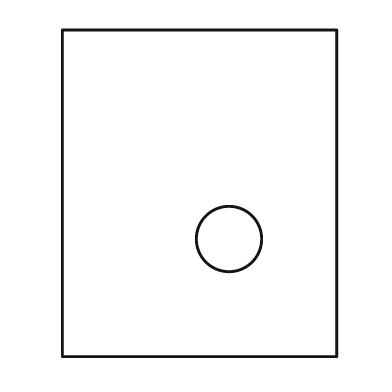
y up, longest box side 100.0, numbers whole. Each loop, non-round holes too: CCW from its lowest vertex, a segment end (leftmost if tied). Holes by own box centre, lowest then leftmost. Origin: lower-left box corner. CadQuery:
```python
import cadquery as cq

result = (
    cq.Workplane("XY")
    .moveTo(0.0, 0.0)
    .lineTo(84.0, 0.0)
    .lineTo(84.0, 100.0)
    .lineTo(0.0, 100.0)
    .close()
    .moveTo(51.0, 36.0)
    .circle(10.0)
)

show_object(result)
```